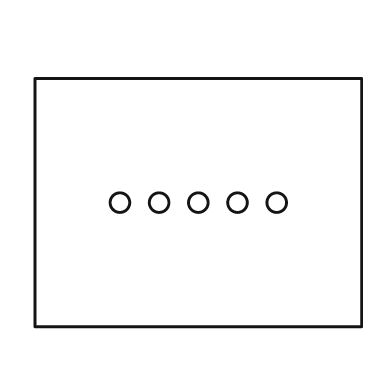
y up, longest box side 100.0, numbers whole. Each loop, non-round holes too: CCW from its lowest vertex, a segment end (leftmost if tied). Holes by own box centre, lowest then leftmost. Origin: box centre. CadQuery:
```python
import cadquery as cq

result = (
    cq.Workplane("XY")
    .moveTo(-50.0, -38.0)
    .lineTo(50.0, -38.0)
    .lineTo(50.0, 38.0)
    .lineTo(-50.0, 38.0)
    .close()
    .moveTo(-24.0, 0.0)
    .circle(3.0)
    .moveTo(-12.0, 0.0)
    .circle(3.0)
    .moveTo(0.0, 0.0)
    .circle(3.0)
    .moveTo(12.0, 0.0)
    .circle(3.0)
    .moveTo(24.0, 0.0)
    .circle(3.0)
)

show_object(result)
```